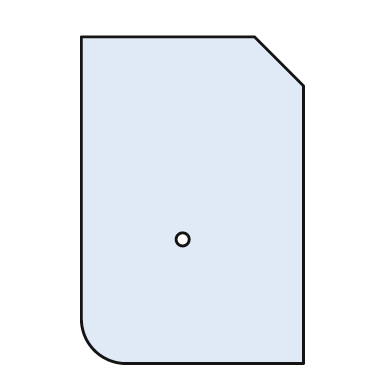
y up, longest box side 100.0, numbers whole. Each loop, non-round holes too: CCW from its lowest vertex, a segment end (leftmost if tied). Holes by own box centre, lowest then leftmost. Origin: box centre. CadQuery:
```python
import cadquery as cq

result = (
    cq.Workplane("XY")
    .moveTo(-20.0, -50.0)
    .lineTo(34.0, -50.0)
    .lineTo(34.0, 35.0)
    .lineTo(19.0, 50.0)
    .lineTo(-34.0, 50.0)
    .lineTo(-34.0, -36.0)
    .threePointArc((-30.0, -46.0), (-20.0, -50.0))
    .close()
    .moveTo(-3.0, -12.0)
    .circle(2.0)
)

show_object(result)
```